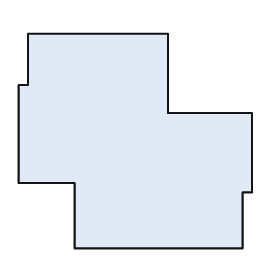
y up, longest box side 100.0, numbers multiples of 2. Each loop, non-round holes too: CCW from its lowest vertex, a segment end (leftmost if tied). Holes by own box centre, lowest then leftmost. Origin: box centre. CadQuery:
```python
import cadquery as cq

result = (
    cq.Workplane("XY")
    .moveTo(-26.0, -46.0)
    .lineTo(46.0, -46.0)
    .lineTo(46.0, -22.0)
    .lineTo(50.0, -22.0)
    .lineTo(50.0, 12.0)
    .lineTo(14.0, 12.0)
    .lineTo(14.0, 46.0)
    .lineTo(-46.0, 46.0)
    .lineTo(-46.0, 24.0)
    .lineTo(-50.0, 24.0)
    .lineTo(-50.0, -18.0)
    .lineTo(-26.0, -18.0)
    .close()
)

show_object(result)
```